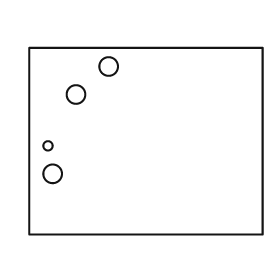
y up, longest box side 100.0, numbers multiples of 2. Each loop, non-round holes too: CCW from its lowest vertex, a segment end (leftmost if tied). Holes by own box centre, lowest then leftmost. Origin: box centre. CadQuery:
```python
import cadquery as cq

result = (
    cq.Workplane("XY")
    .moveTo(-50.0, -40.0)
    .lineTo(50.0, -40.0)
    .lineTo(50.0, 40.0)
    .lineTo(-50.0, 40.0)
    .close()
    .moveTo(-40.0, -14.0)
    .circle(4.0)
    .moveTo(-42.0, -2.0)
    .circle(2.0)
    .moveTo(-30.0, 20.0)
    .circle(4.0)
    .moveTo(-16.0, 32.0)
    .circle(4.0)
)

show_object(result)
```